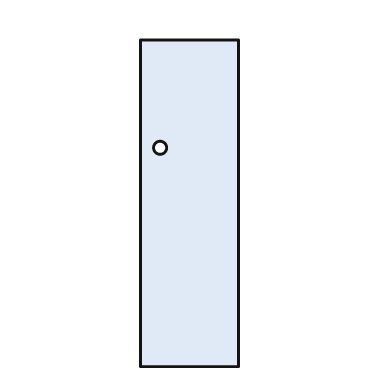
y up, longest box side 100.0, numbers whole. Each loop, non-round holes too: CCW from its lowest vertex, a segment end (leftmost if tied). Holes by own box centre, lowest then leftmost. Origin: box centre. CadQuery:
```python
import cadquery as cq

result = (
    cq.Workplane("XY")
    .moveTo(-15.0, -50.0)
    .lineTo(15.0, -50.0)
    .lineTo(15.0, 50.0)
    .lineTo(-15.0, 50.0)
    .close()
    .moveTo(-9.0, 17.0)
    .circle(2.0)
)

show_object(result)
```